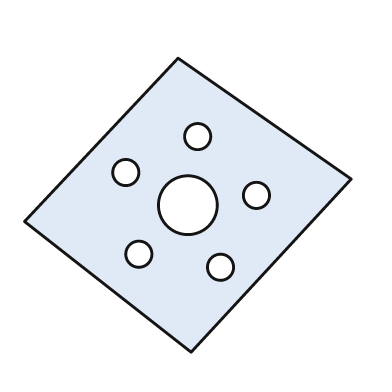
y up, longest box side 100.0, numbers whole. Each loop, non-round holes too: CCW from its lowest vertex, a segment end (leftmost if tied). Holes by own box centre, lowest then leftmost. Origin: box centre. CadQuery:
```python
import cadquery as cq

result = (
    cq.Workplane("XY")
    .moveTo(1.0, -45.0)
    .lineTo(50.0, 8.0)
    .lineTo(-3.0, 45.0)
    .lineTo(-50.0, -5.0)
    .close()
    .moveTo(10.0, -19.0)
    .circle(4.0)
    .moveTo(-15.0, -15.0)
    .circle(4.0)
    .moveTo(0.0, 0.0)
    .circle(9.0)
    .moveTo(21.0, 3.0)
    .circle(4.0)
    .moveTo(-19.0, 10.0)
    .circle(4.0)
    .moveTo(3.0, 21.0)
    .circle(4.0)
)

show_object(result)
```